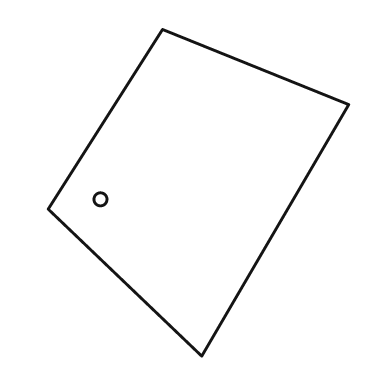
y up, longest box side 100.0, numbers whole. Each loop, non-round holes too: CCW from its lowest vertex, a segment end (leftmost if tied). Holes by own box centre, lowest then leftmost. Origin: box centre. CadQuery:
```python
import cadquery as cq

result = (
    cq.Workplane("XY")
    .moveTo(1.0, -50.0)
    .lineTo(46.0, 27.0)
    .lineTo(-11.0, 50.0)
    .lineTo(-46.0, -5.0)
    .close()
    .moveTo(-30.0, -2.0)
    .circle(2.0)
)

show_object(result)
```